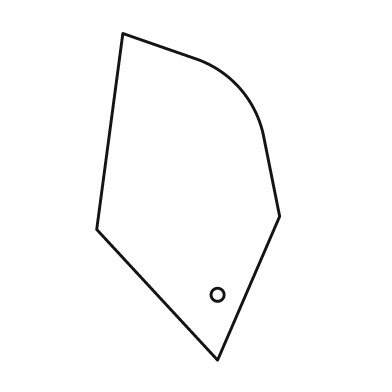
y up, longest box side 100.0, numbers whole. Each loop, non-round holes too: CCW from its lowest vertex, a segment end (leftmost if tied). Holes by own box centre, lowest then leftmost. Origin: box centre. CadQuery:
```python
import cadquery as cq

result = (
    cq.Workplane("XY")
    .moveTo(9.0, -50.0)
    .lineTo(28.0, -6.0)
    .lineTo(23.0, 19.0)
    .threePointArc((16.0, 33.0), (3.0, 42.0))
    .lineTo(-20.0, 50.0)
    .lineTo(-28.0, -10.0)
    .close()
    .moveTo(9.0, -30.0)
    .circle(2.0)
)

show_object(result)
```